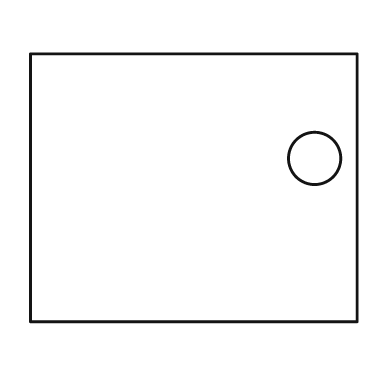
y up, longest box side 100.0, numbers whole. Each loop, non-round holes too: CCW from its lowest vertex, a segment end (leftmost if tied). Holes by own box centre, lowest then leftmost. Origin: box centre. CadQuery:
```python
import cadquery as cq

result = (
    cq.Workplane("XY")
    .moveTo(-50.0, -41.0)
    .lineTo(50.0, -41.0)
    .lineTo(50.0, 41.0)
    .lineTo(-50.0, 41.0)
    .close()
    .moveTo(37.0, 9.0)
    .circle(8.0)
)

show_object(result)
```